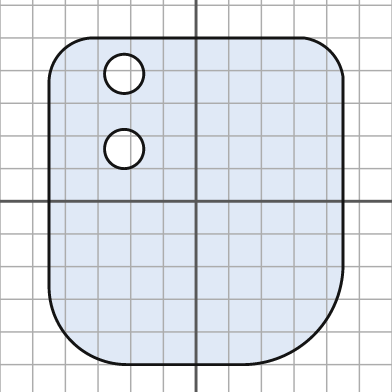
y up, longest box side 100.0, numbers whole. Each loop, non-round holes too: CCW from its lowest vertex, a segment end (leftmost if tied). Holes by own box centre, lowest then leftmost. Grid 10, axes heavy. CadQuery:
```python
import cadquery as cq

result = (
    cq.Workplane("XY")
    .moveTo(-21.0, -50.0)
    .lineTo(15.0, -50.0)
    .threePointArc((36.0, -41.0), (45.0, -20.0))
    .lineTo(45.0, 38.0)
    .threePointArc((41.0, 46.0), (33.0, 50.0))
    .lineTo(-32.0, 50.0)
    .threePointArc((-41.0, 46.0), (-45.0, 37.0))
    .lineTo(-45.0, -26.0)
    .threePointArc((-38.0, -43.0), (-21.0, -50.0))
    .close()
    .moveTo(-22.0, 16.0)
    .circle(6.0)
    .moveTo(-22.0, 39.0)
    .circle(6.0)
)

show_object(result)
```